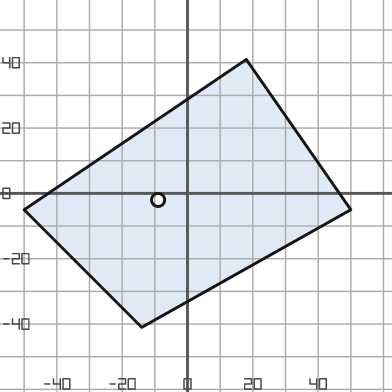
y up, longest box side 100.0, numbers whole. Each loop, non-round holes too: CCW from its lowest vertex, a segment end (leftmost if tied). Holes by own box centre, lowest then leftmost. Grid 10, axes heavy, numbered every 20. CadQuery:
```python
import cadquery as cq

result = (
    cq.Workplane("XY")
    .moveTo(-14.0, -41.0)
    .lineTo(50.0, -5.0)
    .lineTo(18.0, 41.0)
    .lineTo(-50.0, -5.0)
    .close()
    .moveTo(-9.0, -2.0)
    .circle(2.0)
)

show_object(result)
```